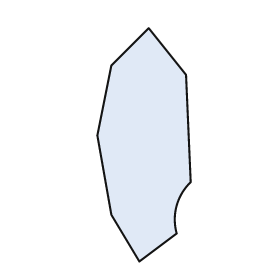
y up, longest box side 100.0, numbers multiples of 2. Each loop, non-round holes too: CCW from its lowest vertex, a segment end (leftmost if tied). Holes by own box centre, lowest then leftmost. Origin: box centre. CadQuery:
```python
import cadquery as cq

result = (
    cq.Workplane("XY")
    .moveTo(-2.0, -50.0)
    .lineTo(14.0, -38.0)
    .threePointArc((14.0, -26.0), (20.0, -16.0))
    .lineTo(18.0, 30.0)
    .lineTo(2.0, 50.0)
    .lineTo(-14.0, 34.0)
    .lineTo(-20.0, 4.0)
    .lineTo(-14.0, -30.0)
    .close()
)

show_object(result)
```